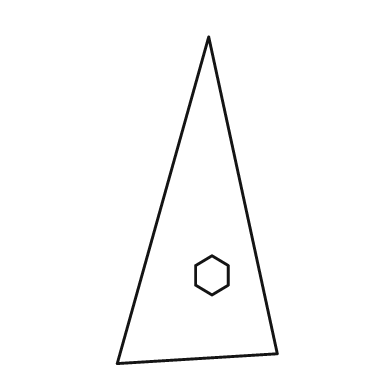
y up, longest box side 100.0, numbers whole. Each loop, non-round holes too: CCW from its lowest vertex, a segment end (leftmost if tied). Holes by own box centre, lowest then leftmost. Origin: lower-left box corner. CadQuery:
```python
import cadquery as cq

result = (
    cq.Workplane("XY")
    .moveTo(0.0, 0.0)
    .lineTo(49.0, 3.0)
    .lineTo(28.0, 100.0)
    .close()
    .moveTo(29.0, 21.0)
    .lineTo(34.0, 24.0)
    .lineTo(34.0, 30.0)
    .lineTo(29.0, 33.0)
    .lineTo(24.0, 30.0)
    .lineTo(24.0, 24.0)
    .close()
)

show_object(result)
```